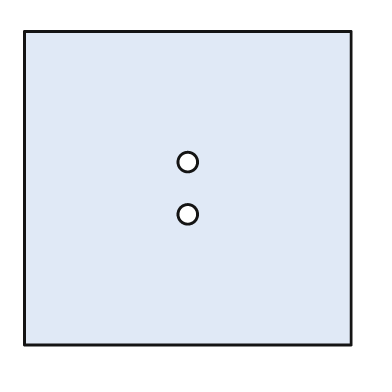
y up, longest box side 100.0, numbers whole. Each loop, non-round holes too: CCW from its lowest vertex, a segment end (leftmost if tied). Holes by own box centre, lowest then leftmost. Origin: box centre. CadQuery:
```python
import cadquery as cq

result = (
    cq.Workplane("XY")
    .moveTo(-50.0, -48.0)
    .lineTo(50.0, -48.0)
    .lineTo(50.0, 48.0)
    .lineTo(-50.0, 48.0)
    .close()
    .moveTo(0.0, -8.0)
    .circle(3.0)
    .moveTo(0.0, 8.0)
    .circle(3.0)
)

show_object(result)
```